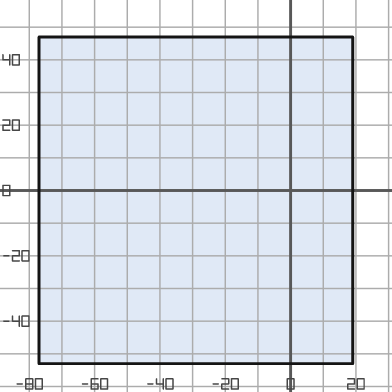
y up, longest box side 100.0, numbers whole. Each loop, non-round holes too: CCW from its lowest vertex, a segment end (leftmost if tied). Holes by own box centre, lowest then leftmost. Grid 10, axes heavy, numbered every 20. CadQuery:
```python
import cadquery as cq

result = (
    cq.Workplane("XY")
    .moveTo(-77.0, -53.0)
    .lineTo(19.0, -53.0)
    .lineTo(19.0, 47.0)
    .lineTo(-77.0, 47.0)
    .close()
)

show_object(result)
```